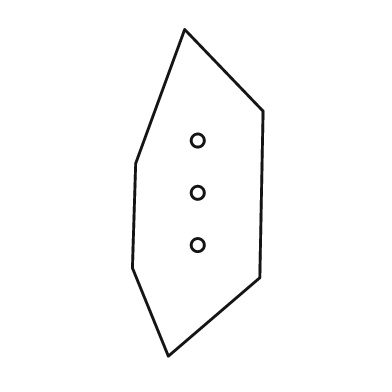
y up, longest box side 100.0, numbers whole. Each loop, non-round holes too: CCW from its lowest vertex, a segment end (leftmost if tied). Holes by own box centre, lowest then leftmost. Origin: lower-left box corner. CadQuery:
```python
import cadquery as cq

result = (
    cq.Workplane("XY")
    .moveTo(11.0, 0.0)
    .lineTo(39.0, 24.0)
    .lineTo(40.0, 75.0)
    .lineTo(16.0, 100.0)
    .lineTo(1.0, 59.0)
    .lineTo(0.0, 27.0)
    .close()
    .moveTo(20.0, 34.0)
    .circle(2.0)
    .moveTo(20.0, 50.0)
    .circle(2.0)
    .moveTo(20.0, 66.0)
    .circle(2.0)
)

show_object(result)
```